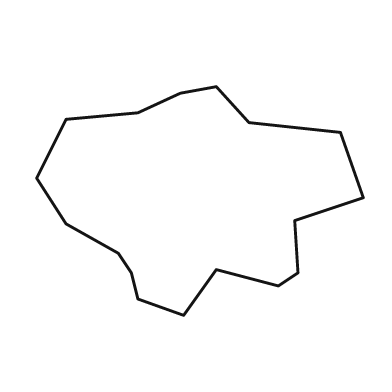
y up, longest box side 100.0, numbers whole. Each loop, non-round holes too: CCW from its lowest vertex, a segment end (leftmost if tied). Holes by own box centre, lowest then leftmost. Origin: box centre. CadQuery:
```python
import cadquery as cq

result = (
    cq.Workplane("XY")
    .moveTo(-5.0, -35.0)
    .lineTo(5.0, -21.0)
    .lineTo(24.0, -26.0)
    .lineTo(30.0, -22.0)
    .lineTo(29.0, -6.0)
    .lineTo(50.0, 1.0)
    .lineTo(43.0, 21.0)
    .lineTo(15.0, 24.0)
    .lineTo(5.0, 35.0)
    .lineTo(-6.0, 33.0)
    .lineTo(-19.0, 27.0)
    .lineTo(-41.0, 25.0)
    .lineTo(-50.0, 7.0)
    .lineTo(-41.0, -7.0)
    .lineTo(-25.0, -16.0)
    .lineTo(-21.0, -22.0)
    .lineTo(-19.0, -30.0)
    .close()
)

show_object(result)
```